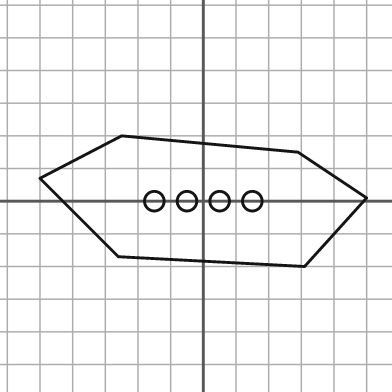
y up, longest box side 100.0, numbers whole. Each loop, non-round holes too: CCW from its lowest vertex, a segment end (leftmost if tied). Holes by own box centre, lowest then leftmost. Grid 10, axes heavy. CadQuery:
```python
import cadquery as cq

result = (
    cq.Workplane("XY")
    .moveTo(31.0, -20.0)
    .lineTo(50.0, 1.0)
    .lineTo(29.0, 15.0)
    .lineTo(-25.0, 20.0)
    .lineTo(-50.0, 7.0)
    .lineTo(-26.0, -17.0)
    .close()
    .moveTo(-15.0, 0.0)
    .circle(3.0)
    .moveTo(-5.0, 0.0)
    .circle(3.0)
    .moveTo(5.0, 0.0)
    .circle(3.0)
    .moveTo(15.0, 0.0)
    .circle(3.0)
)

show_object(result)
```